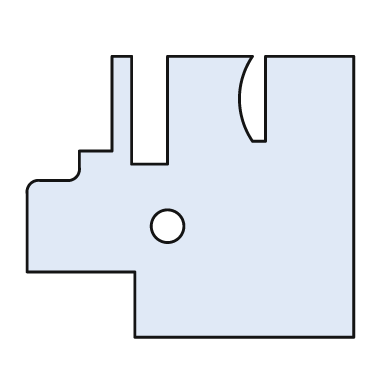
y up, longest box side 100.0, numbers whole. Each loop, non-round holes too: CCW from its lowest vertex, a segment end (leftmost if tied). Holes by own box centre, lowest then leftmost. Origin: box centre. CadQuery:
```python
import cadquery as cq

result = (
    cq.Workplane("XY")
    .moveTo(-17.0, -43.0)
    .lineTo(50.0, -43.0)
    .lineTo(50.0, 43.0)
    .lineTo(23.0, 43.0)
    .lineTo(23.0, 17.0)
    .lineTo(19.0, 17.0)
    .threePointArc((15.0, 30.0), (19.0, 43.0))
    .lineTo(-7.0, 43.0)
    .lineTo(-7.0, 10.0)
    .lineTo(-18.0, 10.0)
    .lineTo(-18.0, 43.0)
    .lineTo(-24.0, 43.0)
    .lineTo(-24.0, 14.0)
    .lineTo(-34.0, 14.0)
    .lineTo(-34.0, 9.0)
    .threePointArc((-35.0, 6.0), (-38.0, 5.0))
    .lineTo(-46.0, 5.0)
    .threePointArc((-49.0, 4.0), (-50.0, 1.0))
    .lineTo(-50.0, -23.0)
    .lineTo(-17.0, -23.0)
    .close()
    .moveTo(-7.0, -9.0)
    .circle(5.0)
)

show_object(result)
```